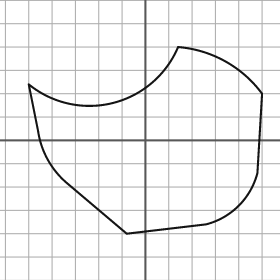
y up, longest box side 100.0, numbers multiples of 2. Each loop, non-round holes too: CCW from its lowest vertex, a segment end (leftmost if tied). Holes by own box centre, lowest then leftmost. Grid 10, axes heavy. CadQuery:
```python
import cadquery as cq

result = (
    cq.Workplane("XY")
    .moveTo(-8.0, -40.0)
    .lineTo(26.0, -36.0)
    .threePointArc((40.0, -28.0), (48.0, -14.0))
    .lineTo(50.0, 20.0)
    .threePointArc((34.0, 34.0), (14.0, 40.0))
    .threePointArc((-14.0, 16.0), (-50.0, 24.0))
    .lineTo(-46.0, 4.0)
    .threePointArc((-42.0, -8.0), (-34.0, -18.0))
    .close()
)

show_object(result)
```